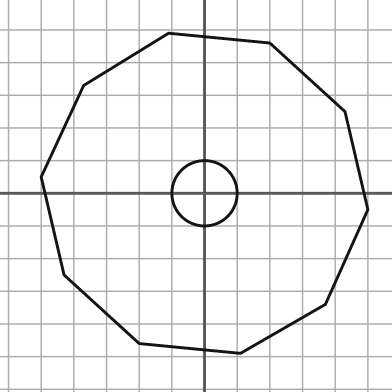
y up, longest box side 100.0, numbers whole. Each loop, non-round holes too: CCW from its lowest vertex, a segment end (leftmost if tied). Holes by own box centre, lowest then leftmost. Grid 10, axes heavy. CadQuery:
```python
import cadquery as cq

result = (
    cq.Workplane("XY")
    .moveTo(11.0, -49.0)
    .lineTo(37.0, -34.0)
    .lineTo(50.0, -5.0)
    .lineTo(43.0, 25.0)
    .lineTo(20.0, 46.0)
    .lineTo(-11.0, 49.0)
    .lineTo(-37.0, 33.0)
    .lineTo(-50.0, 5.0)
    .lineTo(-43.0, -25.0)
    .lineTo(-20.0, -46.0)
    .close()
    .moveTo(0.0, 0.0)
    .circle(10.0)
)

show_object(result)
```